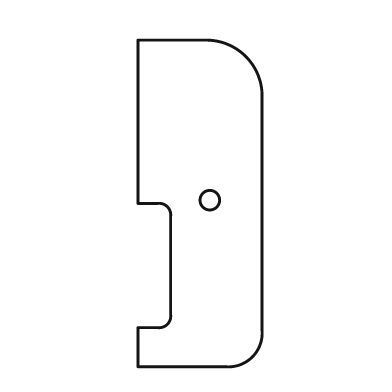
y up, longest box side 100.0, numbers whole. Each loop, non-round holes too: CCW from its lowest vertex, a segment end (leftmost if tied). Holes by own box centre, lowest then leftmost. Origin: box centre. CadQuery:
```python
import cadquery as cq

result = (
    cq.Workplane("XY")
    .moveTo(-19.0, -50.0)
    .lineTo(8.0, -50.0)
    .threePointArc((16.0, -47.0), (19.0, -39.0))
    .lineTo(19.0, 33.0)
    .threePointArc((14.0, 45.0), (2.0, 50.0))
    .lineTo(-19.0, 50.0)
    .lineTo(-19.0, 0.0)
    .lineTo(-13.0, 0.0)
    .threePointArc((-10.0, -1.0), (-9.0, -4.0))
    .lineTo(-9.0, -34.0)
    .threePointArc((-10.0, -37.0), (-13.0, -38.0))
    .lineTo(-19.0, -38.0)
    .close()
    .moveTo(3.0, 1.0)
    .circle(3.0)
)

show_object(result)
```